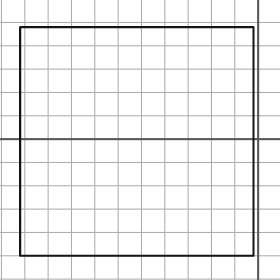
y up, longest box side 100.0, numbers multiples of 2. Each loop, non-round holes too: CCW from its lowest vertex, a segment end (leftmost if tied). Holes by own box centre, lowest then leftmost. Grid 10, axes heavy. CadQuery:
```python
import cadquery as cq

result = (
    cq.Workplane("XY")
    .moveTo(-102.0, -50.0)
    .lineTo(-2.0, -50.0)
    .lineTo(-2.0, 48.0)
    .lineTo(-102.0, 48.0)
    .close()
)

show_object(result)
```